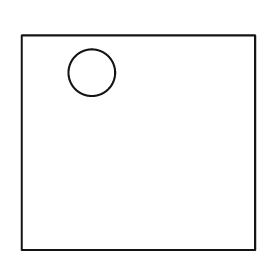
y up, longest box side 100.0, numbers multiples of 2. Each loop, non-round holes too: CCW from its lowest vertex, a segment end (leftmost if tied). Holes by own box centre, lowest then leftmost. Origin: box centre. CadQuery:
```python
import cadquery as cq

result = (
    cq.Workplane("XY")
    .moveTo(-50.0, -46.0)
    .lineTo(50.0, -46.0)
    .lineTo(50.0, 46.0)
    .lineTo(-50.0, 46.0)
    .close()
    .moveTo(-20.0, 30.0)
    .circle(10.0)
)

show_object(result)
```